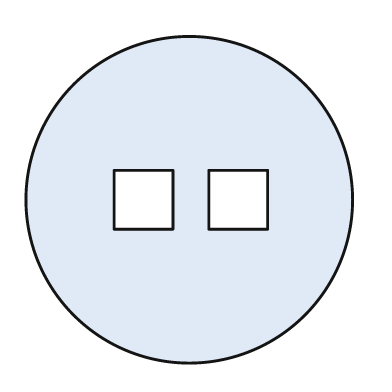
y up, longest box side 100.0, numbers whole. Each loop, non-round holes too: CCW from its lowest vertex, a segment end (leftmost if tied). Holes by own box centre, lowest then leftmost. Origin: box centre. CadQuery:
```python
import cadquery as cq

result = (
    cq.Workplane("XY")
    .moveTo(0.0, 0.0)
    .circle(50.0)
    .moveTo(-23.0, -9.0)
    .lineTo(-5.0, -9.0)
    .lineTo(-5.0, 9.0)
    .lineTo(-23.0, 9.0)
    .close()
    .moveTo(6.0, -9.0)
    .lineTo(24.0, -9.0)
    .lineTo(24.0, 9.0)
    .lineTo(6.0, 9.0)
    .close()
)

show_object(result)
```